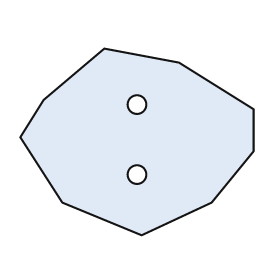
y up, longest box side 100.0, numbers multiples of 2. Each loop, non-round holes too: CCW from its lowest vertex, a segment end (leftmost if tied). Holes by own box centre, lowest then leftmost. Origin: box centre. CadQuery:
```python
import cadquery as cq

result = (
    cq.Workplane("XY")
    .moveTo(2.0, -40.0)
    .lineTo(32.0, -26.0)
    .lineTo(50.0, -4.0)
    .lineTo(50.0, 14.0)
    .lineTo(18.0, 34.0)
    .lineTo(-14.0, 40.0)
    .lineTo(-40.0, 18.0)
    .lineTo(-50.0, 2.0)
    .lineTo(-32.0, -26.0)
    .close()
    .moveTo(0.0, -14.0)
    .circle(4.0)
    .moveTo(0.0, 16.0)
    .circle(4.0)
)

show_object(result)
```